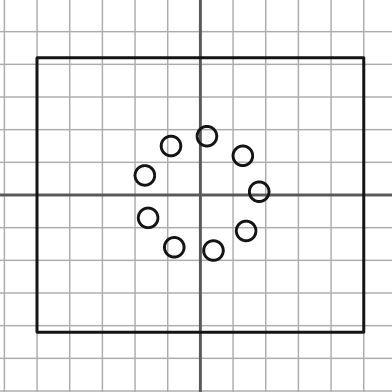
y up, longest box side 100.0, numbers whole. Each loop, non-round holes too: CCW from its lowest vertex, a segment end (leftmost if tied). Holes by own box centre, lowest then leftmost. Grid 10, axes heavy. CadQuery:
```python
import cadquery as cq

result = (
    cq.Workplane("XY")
    .moveTo(-50.0, -42.0)
    .lineTo(50.0, -42.0)
    .lineTo(50.0, 42.0)
    .lineTo(-50.0, 42.0)
    .close()
    .moveTo(4.0, -17.0)
    .circle(3.0)
    .moveTo(-8.0, -16.0)
    .circle(3.0)
    .moveTo(14.0, -11.0)
    .circle(3.0)
    .moveTo(-16.0, -7.0)
    .circle(3.0)
    .moveTo(18.0, 1.0)
    .circle(3.0)
    .moveTo(-17.0, 6.0)
    .circle(3.0)
    .moveTo(13.0, 12.0)
    .circle(3.0)
    .moveTo(-9.0, 15.0)
    .circle(3.0)
    .moveTo(2.0, 18.0)
    .circle(3.0)
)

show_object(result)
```